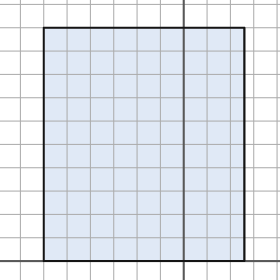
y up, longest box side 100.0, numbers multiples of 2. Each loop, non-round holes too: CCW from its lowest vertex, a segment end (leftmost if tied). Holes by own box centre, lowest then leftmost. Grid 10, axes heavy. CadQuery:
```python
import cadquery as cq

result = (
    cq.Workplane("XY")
    .moveTo(-60.0, 0.0)
    .lineTo(26.0, 0.0)
    .lineTo(26.0, 100.0)
    .lineTo(-60.0, 100.0)
    .close()
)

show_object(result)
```